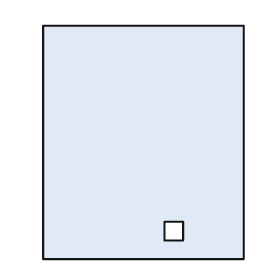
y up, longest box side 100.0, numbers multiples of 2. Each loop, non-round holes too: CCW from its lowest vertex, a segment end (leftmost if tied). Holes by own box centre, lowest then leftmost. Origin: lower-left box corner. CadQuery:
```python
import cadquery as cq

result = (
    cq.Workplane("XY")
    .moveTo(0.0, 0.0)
    .lineTo(86.0, 0.0)
    .lineTo(86.0, 100.0)
    .lineTo(0.0, 100.0)
    .close()
    .moveTo(52.0, 8.0)
    .lineTo(60.0, 8.0)
    .lineTo(60.0, 16.0)
    .lineTo(52.0, 16.0)
    .close()
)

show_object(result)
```